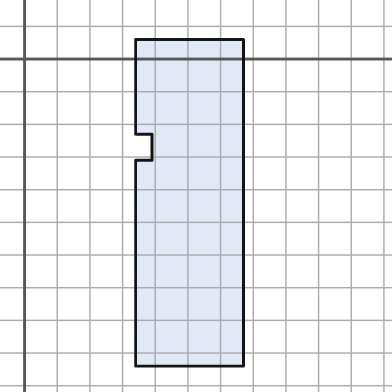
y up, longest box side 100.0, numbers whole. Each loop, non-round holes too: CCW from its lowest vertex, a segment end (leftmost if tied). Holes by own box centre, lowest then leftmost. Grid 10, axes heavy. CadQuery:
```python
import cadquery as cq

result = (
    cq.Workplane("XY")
    .moveTo(34.0, -94.0)
    .lineTo(67.0, -94.0)
    .lineTo(67.0, 6.0)
    .lineTo(34.0, 6.0)
    .lineTo(34.0, -23.0)
    .lineTo(39.0, -23.0)
    .lineTo(39.0, -31.0)
    .lineTo(34.0, -31.0)
    .close()
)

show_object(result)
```